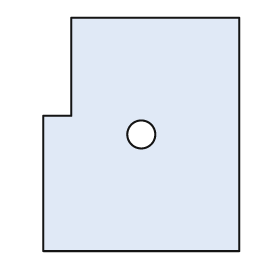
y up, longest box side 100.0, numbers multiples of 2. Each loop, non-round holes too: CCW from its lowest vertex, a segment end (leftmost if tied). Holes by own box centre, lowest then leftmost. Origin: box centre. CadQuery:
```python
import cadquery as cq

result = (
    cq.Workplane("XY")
    .moveTo(-42.0, -50.0)
    .lineTo(42.0, -50.0)
    .lineTo(42.0, 50.0)
    .lineTo(-30.0, 50.0)
    .lineTo(-30.0, 8.0)
    .lineTo(-42.0, 8.0)
    .close()
    .moveTo(0.0, 0.0)
    .circle(6.0)
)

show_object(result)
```